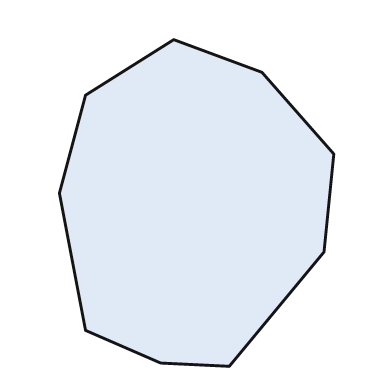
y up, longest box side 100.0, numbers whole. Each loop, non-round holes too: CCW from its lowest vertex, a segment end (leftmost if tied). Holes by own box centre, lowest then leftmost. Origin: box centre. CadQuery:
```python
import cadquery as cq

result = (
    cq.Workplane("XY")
    .moveTo(10.0, -50.0)
    .lineTo(39.0, -15.0)
    .lineTo(42.0, 15.0)
    .lineTo(20.0, 40.0)
    .lineTo(-7.0, 50.0)
    .lineTo(-34.0, 33.0)
    .lineTo(-42.0, 3.0)
    .lineTo(-34.0, -39.0)
    .lineTo(-11.0, -49.0)
    .close()
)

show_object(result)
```